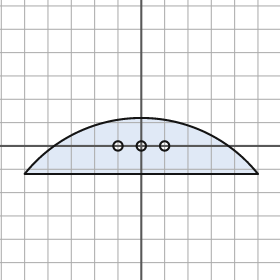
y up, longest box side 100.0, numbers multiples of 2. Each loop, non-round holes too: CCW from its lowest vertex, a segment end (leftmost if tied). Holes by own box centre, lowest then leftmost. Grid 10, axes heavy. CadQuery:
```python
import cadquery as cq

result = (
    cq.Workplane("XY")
    .moveTo(-50.0, -12.0)
    .lineTo(50.0, -12.0)
    .threePointArc((0.0, 12.0), (-50.0, -12.0))
    .close()
    .moveTo(-10.0, 0.0)
    .circle(2.0)
    .moveTo(0.0, 0.0)
    .circle(2.0)
    .moveTo(10.0, 0.0)
    .circle(2.0)
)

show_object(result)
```